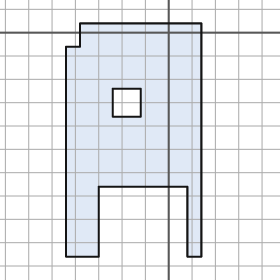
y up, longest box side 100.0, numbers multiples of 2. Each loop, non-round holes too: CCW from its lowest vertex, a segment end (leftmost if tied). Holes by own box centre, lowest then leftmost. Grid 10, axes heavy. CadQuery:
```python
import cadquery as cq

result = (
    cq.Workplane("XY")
    .moveTo(-44.0, -96.0)
    .lineTo(-30.0, -96.0)
    .lineTo(-30.0, -66.0)
    .lineTo(8.0, -66.0)
    .lineTo(8.0, -96.0)
    .lineTo(14.0, -96.0)
    .lineTo(14.0, 4.0)
    .lineTo(-38.0, 4.0)
    .lineTo(-38.0, -6.0)
    .lineTo(-44.0, -6.0)
    .close()
    .moveTo(-24.0, -36.0)
    .lineTo(-12.0, -36.0)
    .lineTo(-12.0, -24.0)
    .lineTo(-24.0, -24.0)
    .close()
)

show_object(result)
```